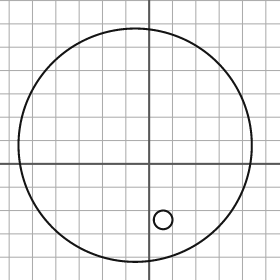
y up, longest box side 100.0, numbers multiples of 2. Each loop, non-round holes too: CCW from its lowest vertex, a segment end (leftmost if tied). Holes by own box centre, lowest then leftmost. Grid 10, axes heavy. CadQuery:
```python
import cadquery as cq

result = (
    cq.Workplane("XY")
    .moveTo(-6.0, 8.0)
    .circle(50.0)
    .moveTo(6.0, -24.0)
    .circle(4.0)
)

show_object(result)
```